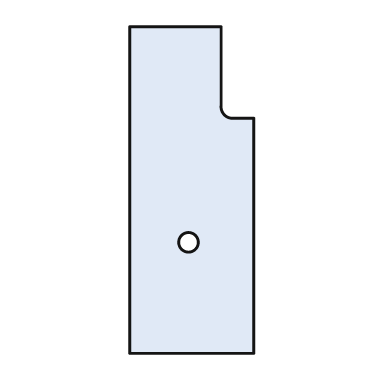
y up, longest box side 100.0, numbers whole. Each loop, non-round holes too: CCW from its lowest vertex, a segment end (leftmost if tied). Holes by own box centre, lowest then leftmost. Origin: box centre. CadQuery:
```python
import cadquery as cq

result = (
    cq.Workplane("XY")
    .moveTo(-19.0, -50.0)
    .lineTo(19.0, -50.0)
    .lineTo(19.0, 22.0)
    .lineTo(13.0, 22.0)
    .threePointArc((10.0, 23.0), (9.0, 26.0))
    .lineTo(9.0, 50.0)
    .lineTo(-19.0, 50.0)
    .close()
    .moveTo(-1.0, -16.0)
    .circle(3.0)
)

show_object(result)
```